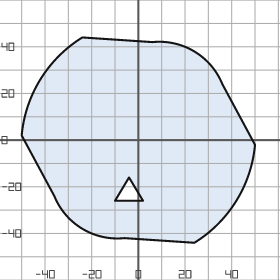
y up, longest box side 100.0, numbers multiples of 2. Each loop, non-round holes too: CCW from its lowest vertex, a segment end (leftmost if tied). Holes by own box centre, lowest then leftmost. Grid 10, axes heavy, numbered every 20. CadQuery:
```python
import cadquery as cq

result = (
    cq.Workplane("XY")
    .moveTo(24.0, -44.0)
    .threePointArc((42.0, -26.0), (50.0, -2.0))
    .lineTo(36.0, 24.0)
    .threePointArc((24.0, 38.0), (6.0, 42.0))
    .lineTo(-24.0, 44.0)
    .threePointArc((-42.0, 26.0), (-50.0, 2.0))
    .lineTo(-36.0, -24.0)
    .threePointArc((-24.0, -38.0), (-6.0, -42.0))
    .close()
    .moveTo(-10.0, -26.0)
    .lineTo(2.0, -26.0)
    .lineTo(-4.0, -16.0)
    .close()
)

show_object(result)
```